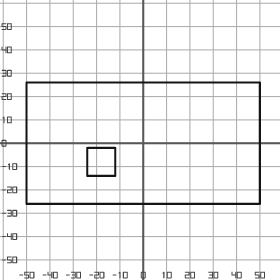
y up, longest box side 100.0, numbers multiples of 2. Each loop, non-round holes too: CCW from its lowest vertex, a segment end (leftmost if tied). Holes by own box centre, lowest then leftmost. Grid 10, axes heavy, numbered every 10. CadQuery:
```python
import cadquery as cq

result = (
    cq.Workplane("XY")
    .moveTo(-50.0, -26.0)
    .lineTo(50.0, -26.0)
    .lineTo(50.0, 26.0)
    .lineTo(-50.0, 26.0)
    .close()
    .moveTo(-24.0, -14.0)
    .lineTo(-12.0, -14.0)
    .lineTo(-12.0, -2.0)
    .lineTo(-24.0, -2.0)
    .close()
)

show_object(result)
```